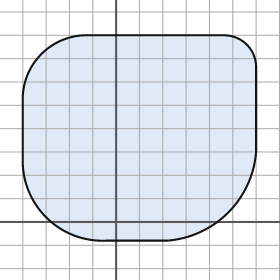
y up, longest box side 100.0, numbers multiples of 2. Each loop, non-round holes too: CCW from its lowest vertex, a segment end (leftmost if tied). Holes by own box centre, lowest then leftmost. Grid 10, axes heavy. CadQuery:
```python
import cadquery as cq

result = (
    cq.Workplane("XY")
    .moveTo(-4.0, -8.0)
    .lineTo(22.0, -8.0)
    .threePointArc((48.0, 4.0), (60.0, 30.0))
    .lineTo(60.0, 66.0)
    .threePointArc((56.0, 76.0), (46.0, 80.0))
    .lineTo(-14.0, 80.0)
    .threePointArc((-32.0, 72.0), (-40.0, 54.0))
    .lineTo(-40.0, 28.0)
    .threePointArc((-30.0, 2.0), (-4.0, -8.0))
    .close()
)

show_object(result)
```